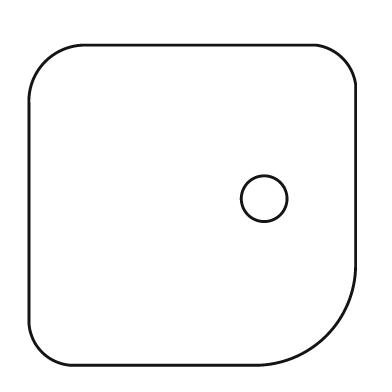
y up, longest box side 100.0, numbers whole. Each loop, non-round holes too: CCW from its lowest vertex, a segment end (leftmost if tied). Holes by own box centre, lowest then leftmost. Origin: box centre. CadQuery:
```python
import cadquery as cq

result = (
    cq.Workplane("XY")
    .moveTo(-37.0, -49.0)
    .lineTo(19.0, -49.0)
    .threePointArc((41.0, -40.0), (50.0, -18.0))
    .lineTo(50.0, 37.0)
    .threePointArc((46.0, 45.0), (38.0, 49.0))
    .lineTo(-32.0, 49.0)
    .threePointArc((-45.0, 44.0), (-50.0, 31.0))
    .lineTo(-50.0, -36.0)
    .threePointArc((-46.0, -45.0), (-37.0, -49.0))
    .close()
    .moveTo(22.0, 2.0)
    .circle(7.0)
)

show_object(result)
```